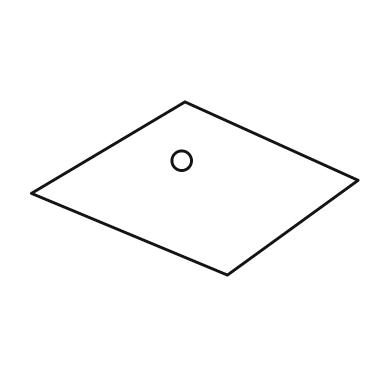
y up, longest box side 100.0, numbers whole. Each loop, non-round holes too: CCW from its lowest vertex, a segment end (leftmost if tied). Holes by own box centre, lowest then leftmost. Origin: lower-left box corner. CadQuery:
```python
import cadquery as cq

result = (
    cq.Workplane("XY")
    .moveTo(60.0, 0.0)
    .lineTo(100.0, 29.0)
    .lineTo(47.0, 53.0)
    .lineTo(0.0, 25.0)
    .close()
    .moveTo(46.0, 35.0)
    .circle(3.0)
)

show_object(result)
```